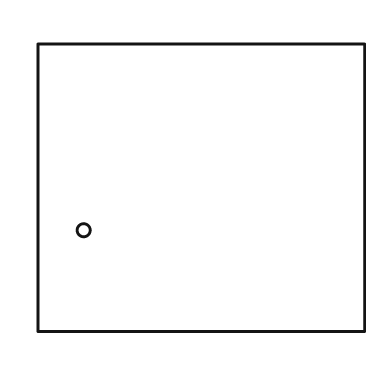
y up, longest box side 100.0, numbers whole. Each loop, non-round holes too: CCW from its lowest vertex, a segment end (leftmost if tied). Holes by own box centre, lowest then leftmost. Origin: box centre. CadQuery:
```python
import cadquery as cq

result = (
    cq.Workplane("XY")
    .moveTo(-50.0, -44.0)
    .lineTo(50.0, -44.0)
    .lineTo(50.0, 44.0)
    .lineTo(-50.0, 44.0)
    .close()
    .moveTo(-36.0, -13.0)
    .circle(2.0)
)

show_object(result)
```